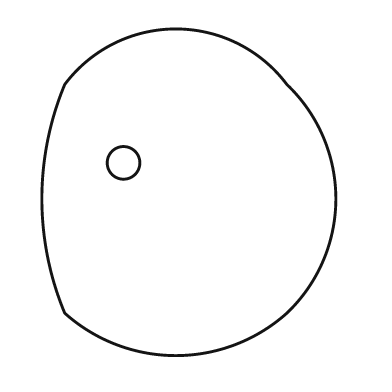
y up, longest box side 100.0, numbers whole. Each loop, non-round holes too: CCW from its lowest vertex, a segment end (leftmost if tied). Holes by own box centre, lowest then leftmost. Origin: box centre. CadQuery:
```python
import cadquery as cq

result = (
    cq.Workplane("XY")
    .moveTo(-38.0, -37.0)
    .threePointArc((-4.0, -50.0), (30.0, -37.0))
    .threePointArc((45.0, -2.0), (30.0, 33.0))
    .threePointArc((-4.0, 50.0), (-38.0, 33.0))
    .threePointArc((-45.0, -2.0), (-38.0, -37.0))
    .close()
    .moveTo(-20.0, 9.0)
    .circle(5.0)
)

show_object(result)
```